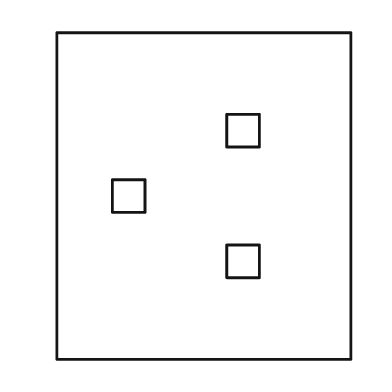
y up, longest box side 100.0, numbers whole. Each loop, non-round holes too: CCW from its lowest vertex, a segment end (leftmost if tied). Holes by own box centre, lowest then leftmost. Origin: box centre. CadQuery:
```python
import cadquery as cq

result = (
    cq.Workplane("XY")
    .moveTo(-45.0, -50.0)
    .lineTo(45.0, -50.0)
    .lineTo(45.0, 50.0)
    .lineTo(-45.0, 50.0)
    .close()
    .moveTo(7.0, -25.0)
    .lineTo(17.0, -25.0)
    .lineTo(17.0, -15.0)
    .lineTo(7.0, -15.0)
    .close()
    .moveTo(-28.0, -5.0)
    .lineTo(-18.0, -5.0)
    .lineTo(-18.0, 5.0)
    .lineTo(-28.0, 5.0)
    .close()
    .moveTo(7.0, 15.0)
    .lineTo(17.0, 15.0)
    .lineTo(17.0, 25.0)
    .lineTo(7.0, 25.0)
    .close()
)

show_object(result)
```